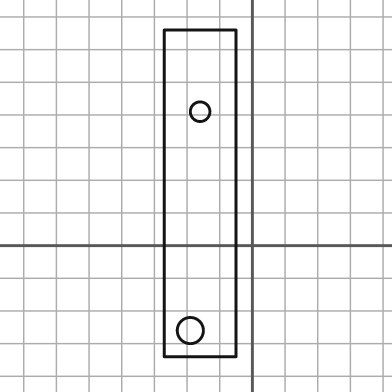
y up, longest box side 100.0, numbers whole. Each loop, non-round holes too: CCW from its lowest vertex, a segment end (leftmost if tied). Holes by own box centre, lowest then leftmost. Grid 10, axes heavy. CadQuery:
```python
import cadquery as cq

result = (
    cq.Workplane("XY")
    .moveTo(-27.0, -34.0)
    .lineTo(-5.0, -34.0)
    .lineTo(-5.0, 66.0)
    .lineTo(-27.0, 66.0)
    .close()
    .moveTo(-19.0, -26.0)
    .circle(4.0)
    .moveTo(-16.0, 41.0)
    .circle(3.0)
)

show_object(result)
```